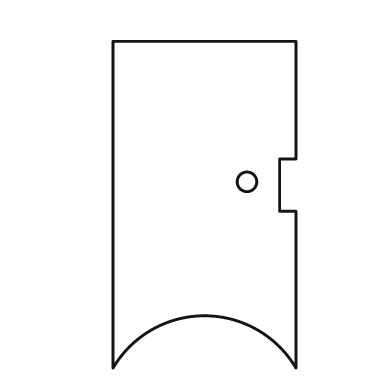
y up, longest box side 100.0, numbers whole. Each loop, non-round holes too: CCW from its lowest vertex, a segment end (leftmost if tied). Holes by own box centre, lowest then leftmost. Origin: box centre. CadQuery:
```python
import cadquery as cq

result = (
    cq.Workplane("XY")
    .moveTo(-28.0, -50.0)
    .threePointArc((0.0, -34.0), (28.0, -50.0))
    .lineTo(28.0, -2.0)
    .lineTo(23.0, -2.0)
    .lineTo(23.0, 14.0)
    .lineTo(28.0, 14.0)
    .lineTo(28.0, 50.0)
    .lineTo(-28.0, 50.0)
    .close()
    .moveTo(13.0, 7.0)
    .circle(3.0)
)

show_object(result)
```